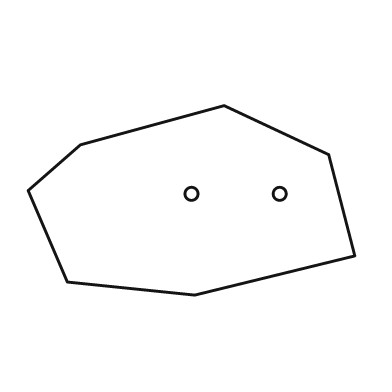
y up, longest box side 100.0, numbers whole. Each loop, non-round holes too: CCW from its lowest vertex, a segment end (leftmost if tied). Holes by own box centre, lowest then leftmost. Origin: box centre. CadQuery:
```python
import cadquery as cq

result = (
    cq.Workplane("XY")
    .moveTo(1.0, -29.0)
    .lineTo(50.0, -17.0)
    .lineTo(42.0, 14.0)
    .lineTo(10.0, 29.0)
    .lineTo(-34.0, 17.0)
    .lineTo(-50.0, 3.0)
    .lineTo(-38.0, -25.0)
    .close()
    .moveTo(0.0, 2.0)
    .circle(2.0)
    .moveTo(27.0, 2.0)
    .circle(2.0)
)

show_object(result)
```